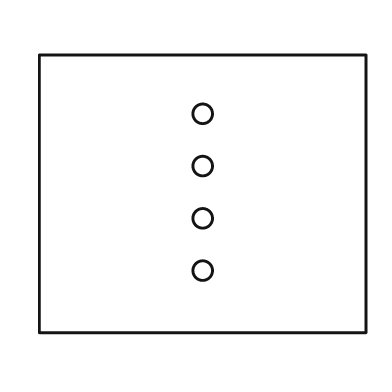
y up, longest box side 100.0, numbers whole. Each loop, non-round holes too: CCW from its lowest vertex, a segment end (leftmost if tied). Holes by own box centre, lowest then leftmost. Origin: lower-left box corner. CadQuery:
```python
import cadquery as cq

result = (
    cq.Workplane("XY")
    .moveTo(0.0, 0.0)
    .lineTo(100.0, 0.0)
    .lineTo(100.0, 85.0)
    .lineTo(0.0, 85.0)
    .close()
    .moveTo(50.0, 19.0)
    .circle(3.0)
    .moveTo(50.0, 35.0)
    .circle(3.0)
    .moveTo(50.0, 51.0)
    .circle(3.0)
    .moveTo(50.0, 67.0)
    .circle(3.0)
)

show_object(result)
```